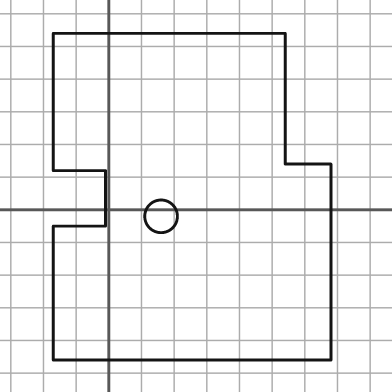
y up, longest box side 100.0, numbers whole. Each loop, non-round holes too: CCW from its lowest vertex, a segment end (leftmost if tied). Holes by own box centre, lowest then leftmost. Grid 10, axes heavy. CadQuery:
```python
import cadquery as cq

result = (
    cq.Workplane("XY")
    .moveTo(-17.0, -46.0)
    .lineTo(68.0, -46.0)
    .lineTo(68.0, 14.0)
    .lineTo(54.0, 14.0)
    .lineTo(54.0, 54.0)
    .lineTo(-17.0, 54.0)
    .lineTo(-17.0, 12.0)
    .lineTo(-1.0, 12.0)
    .lineTo(-1.0, -5.0)
    .lineTo(-17.0, -5.0)
    .close()
    .moveTo(16.0, -2.0)
    .circle(5.0)
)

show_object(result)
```